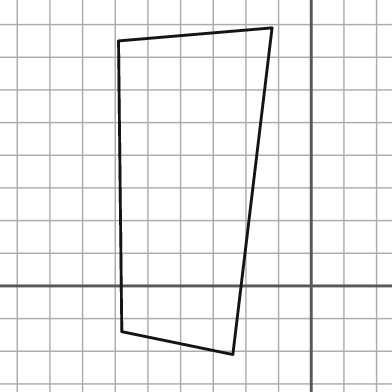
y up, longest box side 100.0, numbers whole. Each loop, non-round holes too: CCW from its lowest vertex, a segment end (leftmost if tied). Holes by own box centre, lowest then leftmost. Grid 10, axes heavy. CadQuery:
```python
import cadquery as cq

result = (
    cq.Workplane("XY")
    .moveTo(-24.0, -21.0)
    .lineTo(-12.0, 79.0)
    .lineTo(-59.0, 75.0)
    .lineTo(-58.0, -14.0)
    .close()
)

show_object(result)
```